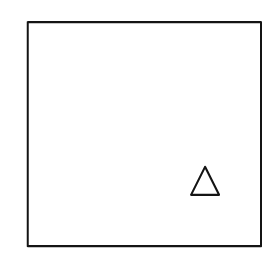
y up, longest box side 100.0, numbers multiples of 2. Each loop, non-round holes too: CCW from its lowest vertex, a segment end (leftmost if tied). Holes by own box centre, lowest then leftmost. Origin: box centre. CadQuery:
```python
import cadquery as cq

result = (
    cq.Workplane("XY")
    .moveTo(-50.0, -48.0)
    .lineTo(50.0, -48.0)
    .lineTo(50.0, 48.0)
    .lineTo(-50.0, 48.0)
    .close()
    .moveTo(20.0, -26.0)
    .lineTo(32.0, -26.0)
    .lineTo(26.0, -14.0)
    .close()
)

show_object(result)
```